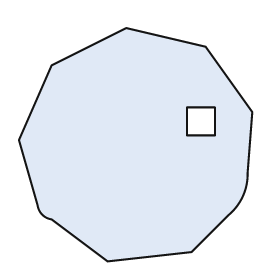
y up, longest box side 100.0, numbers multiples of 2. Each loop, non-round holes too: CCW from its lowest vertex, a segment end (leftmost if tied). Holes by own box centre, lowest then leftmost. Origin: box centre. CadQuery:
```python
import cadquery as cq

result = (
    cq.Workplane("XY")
    .moveTo(-12.0, -50.0)
    .lineTo(24.0, -46.0)
    .lineTo(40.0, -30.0)
    .threePointArc((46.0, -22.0), (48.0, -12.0))
    .lineTo(50.0, 14.0)
    .lineTo(30.0, 42.0)
    .lineTo(-4.0, 50.0)
    .lineTo(-36.0, 34.0)
    .lineTo(-50.0, 2.0)
    .lineTo(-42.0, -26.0)
    .threePointArc((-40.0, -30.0), (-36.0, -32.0))
    .close()
    .moveTo(22.0, 4.0)
    .lineTo(34.0, 4.0)
    .lineTo(34.0, 16.0)
    .lineTo(22.0, 16.0)
    .close()
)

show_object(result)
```